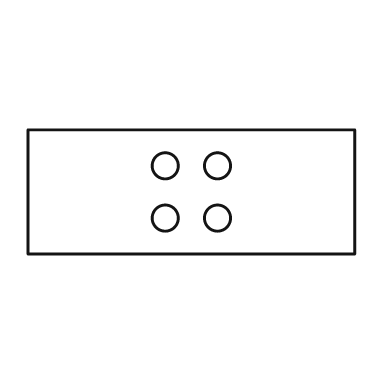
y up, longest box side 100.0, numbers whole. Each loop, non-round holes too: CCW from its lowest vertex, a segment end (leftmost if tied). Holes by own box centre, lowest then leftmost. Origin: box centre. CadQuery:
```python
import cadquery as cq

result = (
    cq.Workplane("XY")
    .moveTo(-50.0, -19.0)
    .lineTo(50.0, -19.0)
    .lineTo(50.0, 19.0)
    .lineTo(-50.0, 19.0)
    .close()
    .moveTo(-8.0, -8.0)
    .circle(4.0)
    .moveTo(8.0, -8.0)
    .circle(4.0)
    .moveTo(-8.0, 8.0)
    .circle(4.0)
    .moveTo(8.0, 8.0)
    .circle(4.0)
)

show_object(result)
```